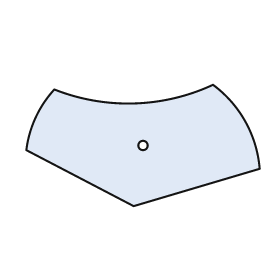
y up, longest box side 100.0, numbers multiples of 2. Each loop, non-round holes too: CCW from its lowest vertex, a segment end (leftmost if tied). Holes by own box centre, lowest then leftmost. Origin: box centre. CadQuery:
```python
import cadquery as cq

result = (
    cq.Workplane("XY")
    .moveTo(-4.0, -26.0)
    .lineTo(50.0, -10.0)
    .threePointArc((44.0, 10.0), (30.0, 26.0))
    .threePointArc((-4.0, 18.0), (-38.0, 24.0))
    .threePointArc((-46.0, 12.0), (-50.0, -2.0))
    .close()
    .moveTo(0.0, 0.0)
    .circle(2.0)
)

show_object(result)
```